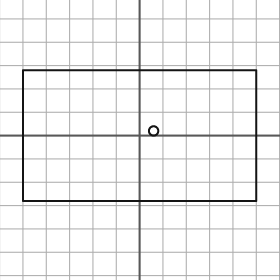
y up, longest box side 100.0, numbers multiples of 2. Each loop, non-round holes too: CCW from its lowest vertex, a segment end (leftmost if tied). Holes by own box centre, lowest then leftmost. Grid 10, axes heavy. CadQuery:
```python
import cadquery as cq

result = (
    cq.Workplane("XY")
    .moveTo(-50.0, -28.0)
    .lineTo(50.0, -28.0)
    .lineTo(50.0, 28.0)
    .lineTo(-50.0, 28.0)
    .close()
    .moveTo(6.0, 2.0)
    .circle(2.0)
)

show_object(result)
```